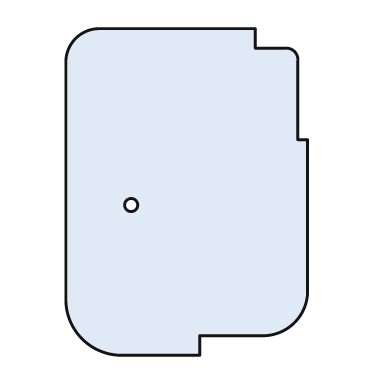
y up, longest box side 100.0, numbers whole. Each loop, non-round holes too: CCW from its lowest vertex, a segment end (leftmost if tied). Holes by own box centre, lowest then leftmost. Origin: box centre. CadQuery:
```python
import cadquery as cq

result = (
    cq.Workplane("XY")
    .moveTo(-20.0, -50.0)
    .lineTo(4.0, -50.0)
    .lineTo(4.0, -44.0)
    .lineTo(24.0, -44.0)
    .threePointArc((33.0, -40.0), (37.0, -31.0))
    .lineTo(37.0, 16.0)
    .lineTo(34.0, 16.0)
    .lineTo(34.0, 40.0)
    .threePointArc((33.0, 43.0), (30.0, 44.0))
    .lineTo(21.0, 44.0)
    .lineTo(21.0, 50.0)
    .lineTo(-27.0, 50.0)
    .threePointArc((-34.0, 47.0), (-37.0, 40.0))
    .lineTo(-37.0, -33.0)
    .threePointArc((-32.0, -45.0), (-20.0, -50.0))
    .close()
    .moveTo(-17.0, -4.0)
    .circle(2.0)
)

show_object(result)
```